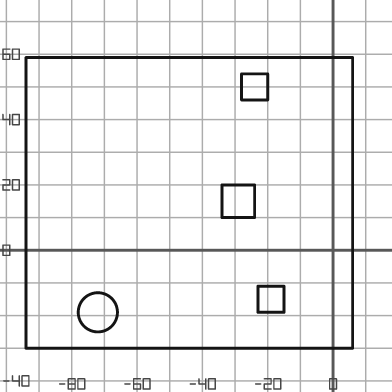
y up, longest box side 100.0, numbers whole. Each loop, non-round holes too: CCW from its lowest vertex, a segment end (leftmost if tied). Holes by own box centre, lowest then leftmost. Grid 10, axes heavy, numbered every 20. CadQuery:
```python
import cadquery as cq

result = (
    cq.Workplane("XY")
    .moveTo(-94.0, -30.0)
    .lineTo(6.0, -30.0)
    .lineTo(6.0, 59.0)
    .lineTo(-94.0, 59.0)
    .close()
    .moveTo(-72.0, -19.0)
    .circle(6.0)
    .moveTo(-23.0, -19.0)
    .lineTo(-15.0, -19.0)
    .lineTo(-15.0, -11.0)
    .lineTo(-23.0, -11.0)
    .close()
    .moveTo(-34.0, 10.0)
    .lineTo(-24.0, 10.0)
    .lineTo(-24.0, 20.0)
    .lineTo(-34.0, 20.0)
    .close()
    .moveTo(-28.0, 46.0)
    .lineTo(-20.0, 46.0)
    .lineTo(-20.0, 54.0)
    .lineTo(-28.0, 54.0)
    .close()
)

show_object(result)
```